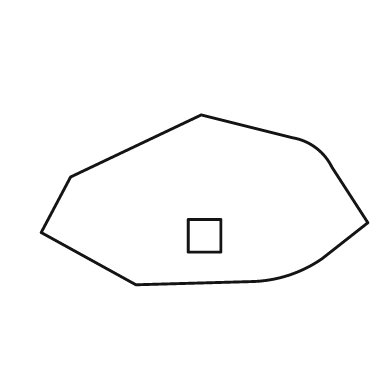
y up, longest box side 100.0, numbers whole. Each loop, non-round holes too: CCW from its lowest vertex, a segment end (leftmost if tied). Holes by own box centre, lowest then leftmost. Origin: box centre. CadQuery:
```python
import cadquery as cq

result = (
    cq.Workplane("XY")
    .moveTo(-21.0, -26.0)
    .lineTo(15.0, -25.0)
    .threePointArc((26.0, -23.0), (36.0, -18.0))
    .lineTo(50.0, -7.0)
    .lineTo(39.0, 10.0)
    .threePointArc((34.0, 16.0), (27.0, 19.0))
    .lineTo(-1.0, 26.0)
    .lineTo(-41.0, 7.0)
    .lineTo(-50.0, -10.0)
    .close()
    .moveTo(-5.0, -16.0)
    .lineTo(5.0, -16.0)
    .lineTo(5.0, -6.0)
    .lineTo(-5.0, -6.0)
    .close()
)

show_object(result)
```